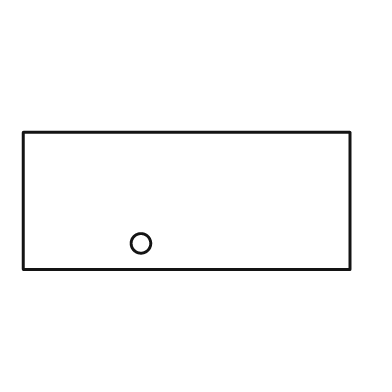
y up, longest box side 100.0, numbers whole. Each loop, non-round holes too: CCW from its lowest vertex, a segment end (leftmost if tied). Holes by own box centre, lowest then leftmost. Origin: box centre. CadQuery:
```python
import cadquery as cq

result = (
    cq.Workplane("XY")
    .moveTo(-50.0, -21.0)
    .lineTo(50.0, -21.0)
    .lineTo(50.0, 21.0)
    .lineTo(-50.0, 21.0)
    .close()
    .moveTo(-14.0, -13.0)
    .circle(3.0)
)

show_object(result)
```